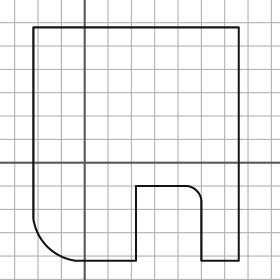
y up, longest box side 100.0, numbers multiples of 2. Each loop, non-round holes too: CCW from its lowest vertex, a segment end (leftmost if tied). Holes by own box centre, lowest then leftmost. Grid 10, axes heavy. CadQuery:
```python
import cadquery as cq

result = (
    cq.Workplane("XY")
    .moveTo(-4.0, -42.0)
    .lineTo(22.0, -42.0)
    .lineTo(22.0, -10.0)
    .lineTo(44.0, -10.0)
    .threePointArc((48.0, -12.0), (50.0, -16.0))
    .lineTo(50.0, -42.0)
    .lineTo(66.0, -42.0)
    .lineTo(66.0, 58.0)
    .lineTo(-22.0, 58.0)
    .lineTo(-22.0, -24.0)
    .threePointArc((-16.0, -36.0), (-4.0, -42.0))
    .close()
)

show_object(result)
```